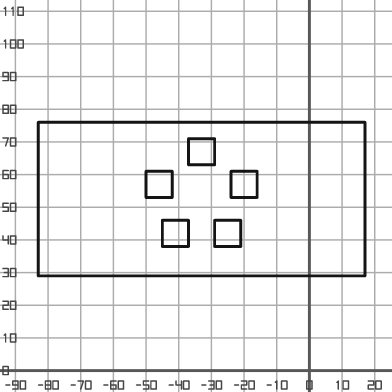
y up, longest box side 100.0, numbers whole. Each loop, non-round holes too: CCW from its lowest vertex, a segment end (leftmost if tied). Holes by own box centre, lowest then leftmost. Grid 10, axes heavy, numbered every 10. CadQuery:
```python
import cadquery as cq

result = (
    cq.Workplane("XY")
    .moveTo(-83.0, 29.0)
    .lineTo(17.0, 29.0)
    .lineTo(17.0, 76.0)
    .lineTo(-83.0, 76.0)
    .close()
    .moveTo(-45.0, 38.0)
    .lineTo(-37.0, 38.0)
    .lineTo(-37.0, 46.0)
    .lineTo(-45.0, 46.0)
    .close()
    .moveTo(-29.0, 38.0)
    .lineTo(-21.0, 38.0)
    .lineTo(-21.0, 46.0)
    .lineTo(-29.0, 46.0)
    .close()
    .moveTo(-50.0, 53.0)
    .lineTo(-42.0, 53.0)
    .lineTo(-42.0, 61.0)
    .lineTo(-50.0, 61.0)
    .close()
    .moveTo(-24.0, 53.0)
    .lineTo(-16.0, 53.0)
    .lineTo(-16.0, 61.0)
    .lineTo(-24.0, 61.0)
    .close()
    .moveTo(-37.0, 63.0)
    .lineTo(-29.0, 63.0)
    .lineTo(-29.0, 71.0)
    .lineTo(-37.0, 71.0)
    .close()
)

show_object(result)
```